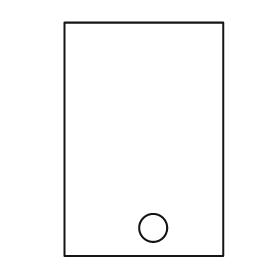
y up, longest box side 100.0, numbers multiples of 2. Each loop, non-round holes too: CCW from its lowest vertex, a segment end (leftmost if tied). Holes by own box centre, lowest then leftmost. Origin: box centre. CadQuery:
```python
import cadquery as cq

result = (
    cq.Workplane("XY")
    .moveTo(-34.0, -50.0)
    .lineTo(34.0, -50.0)
    .lineTo(34.0, 50.0)
    .lineTo(-34.0, 50.0)
    .close()
    .moveTo(4.0, -38.0)
    .circle(6.0)
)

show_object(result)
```